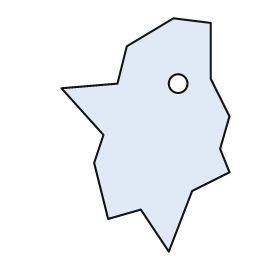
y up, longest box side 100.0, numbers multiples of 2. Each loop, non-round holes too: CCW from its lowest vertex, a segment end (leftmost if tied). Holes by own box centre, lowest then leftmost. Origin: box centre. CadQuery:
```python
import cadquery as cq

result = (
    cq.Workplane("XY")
    .moveTo(10.0, -50.0)
    .lineTo(20.0, -24.0)
    .lineTo(36.0, -16.0)
    .lineTo(32.0, -6.0)
    .lineTo(36.0, 8.0)
    .lineTo(28.0, 24.0)
    .lineTo(28.0, 48.0)
    .lineTo(12.0, 50.0)
    .lineTo(-8.0, 38.0)
    .lineTo(-12.0, 22.0)
    .lineTo(-36.0, 20.0)
    .lineTo(-18.0, 0.0)
    .lineTo(-22.0, -12.0)
    .lineTo(-16.0, -36.0)
    .lineTo(-2.0, -32.0)
    .close()
    .moveTo(14.0, 22.0)
    .circle(4.0)
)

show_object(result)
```